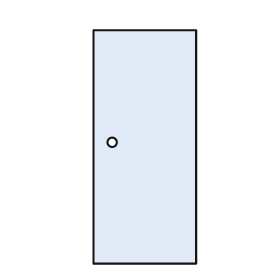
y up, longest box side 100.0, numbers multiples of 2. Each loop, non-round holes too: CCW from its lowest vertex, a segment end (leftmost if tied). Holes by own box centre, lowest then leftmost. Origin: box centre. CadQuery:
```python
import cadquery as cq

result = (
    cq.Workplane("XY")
    .moveTo(-22.0, -50.0)
    .lineTo(22.0, -50.0)
    .lineTo(22.0, 50.0)
    .lineTo(-22.0, 50.0)
    .close()
    .moveTo(-14.0, 2.0)
    .circle(2.0)
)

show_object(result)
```